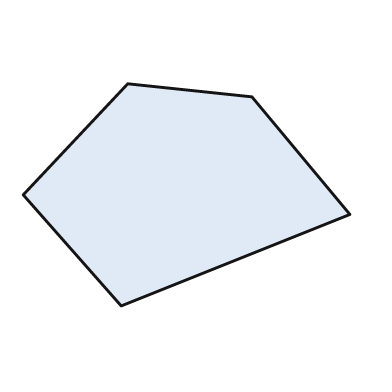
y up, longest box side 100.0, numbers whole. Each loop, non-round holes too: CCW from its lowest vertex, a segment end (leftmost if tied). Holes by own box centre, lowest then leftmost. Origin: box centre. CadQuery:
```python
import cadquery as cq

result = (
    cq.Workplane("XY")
    .moveTo(-20.0, -34.0)
    .lineTo(50.0, -6.0)
    .lineTo(20.0, 30.0)
    .lineTo(-18.0, 34.0)
    .lineTo(-50.0, 0.0)
    .close()
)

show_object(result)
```